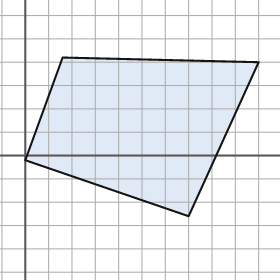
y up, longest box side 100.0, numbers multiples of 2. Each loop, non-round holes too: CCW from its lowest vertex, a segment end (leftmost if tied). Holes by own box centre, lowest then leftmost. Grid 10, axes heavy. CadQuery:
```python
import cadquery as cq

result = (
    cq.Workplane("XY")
    .moveTo(70.0, -26.0)
    .lineTo(100.0, 40.0)
    .lineTo(16.0, 42.0)
    .lineTo(0.0, -2.0)
    .close()
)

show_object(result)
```